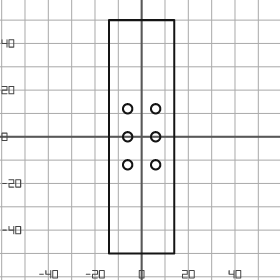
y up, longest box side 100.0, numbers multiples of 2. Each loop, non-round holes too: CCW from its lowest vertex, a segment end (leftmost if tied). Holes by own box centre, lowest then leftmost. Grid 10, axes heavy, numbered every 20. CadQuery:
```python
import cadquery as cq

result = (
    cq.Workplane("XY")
    .moveTo(-14.0, -50.0)
    .lineTo(14.0, -50.0)
    .lineTo(14.0, 50.0)
    .lineTo(-14.0, 50.0)
    .close()
    .moveTo(-6.0, -12.0)
    .circle(2.0)
    .moveTo(6.0, -12.0)
    .circle(2.0)
    .moveTo(-6.0, 0.0)
    .circle(2.0)
    .moveTo(6.0, 0.0)
    .circle(2.0)
    .moveTo(-6.0, 12.0)
    .circle(2.0)
    .moveTo(6.0, 12.0)
    .circle(2.0)
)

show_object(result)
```